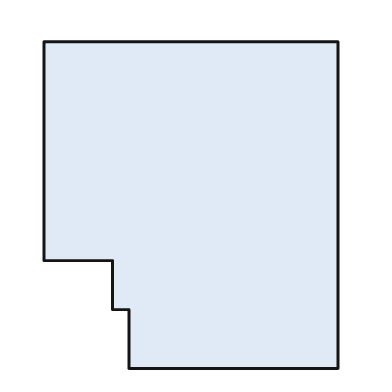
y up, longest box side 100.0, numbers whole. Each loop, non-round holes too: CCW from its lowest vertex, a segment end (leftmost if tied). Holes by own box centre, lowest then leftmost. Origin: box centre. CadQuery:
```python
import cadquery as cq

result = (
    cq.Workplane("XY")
    .moveTo(-19.0, -50.0)
    .lineTo(45.0, -50.0)
    .lineTo(45.0, 50.0)
    .lineTo(-45.0, 50.0)
    .lineTo(-45.0, -17.0)
    .lineTo(-24.0, -17.0)
    .lineTo(-24.0, -32.0)
    .lineTo(-19.0, -32.0)
    .close()
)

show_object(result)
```